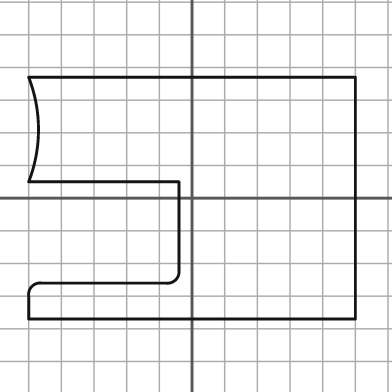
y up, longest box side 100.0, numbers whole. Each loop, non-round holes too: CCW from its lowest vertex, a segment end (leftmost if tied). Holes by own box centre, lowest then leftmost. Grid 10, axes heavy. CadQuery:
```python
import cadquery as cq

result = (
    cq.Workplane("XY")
    .moveTo(-50.0, -37.0)
    .lineTo(50.0, -37.0)
    .lineTo(50.0, 37.0)
    .lineTo(-50.0, 37.0)
    .threePointArc((-47.0, 21.0), (-50.0, 5.0))
    .lineTo(-4.0, 5.0)
    .lineTo(-4.0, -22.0)
    .threePointArc((-5.0, -25.0), (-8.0, -26.0))
    .lineTo(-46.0, -26.0)
    .threePointArc((-49.0, -27.0), (-50.0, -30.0))
    .close()
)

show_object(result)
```